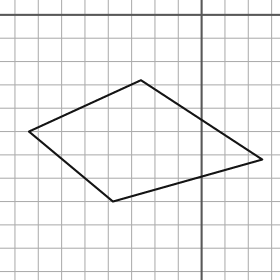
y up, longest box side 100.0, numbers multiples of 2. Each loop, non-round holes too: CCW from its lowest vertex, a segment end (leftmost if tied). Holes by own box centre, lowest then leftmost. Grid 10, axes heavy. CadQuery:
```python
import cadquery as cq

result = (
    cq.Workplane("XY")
    .moveTo(-38.0, -80.0)
    .lineTo(26.0, -62.0)
    .lineTo(-26.0, -28.0)
    .lineTo(-74.0, -50.0)
    .close()
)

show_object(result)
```